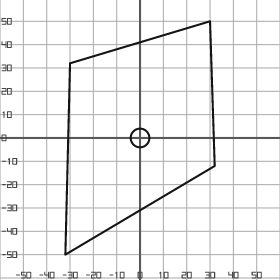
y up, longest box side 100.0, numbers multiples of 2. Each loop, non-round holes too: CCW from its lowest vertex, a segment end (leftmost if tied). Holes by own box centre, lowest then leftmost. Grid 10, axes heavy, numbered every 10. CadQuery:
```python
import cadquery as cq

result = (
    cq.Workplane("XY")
    .moveTo(-32.0, -50.0)
    .lineTo(32.0, -12.0)
    .lineTo(30.0, 50.0)
    .lineTo(-30.0, 32.0)
    .close()
    .moveTo(0.0, 0.0)
    .circle(4.0)
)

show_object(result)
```